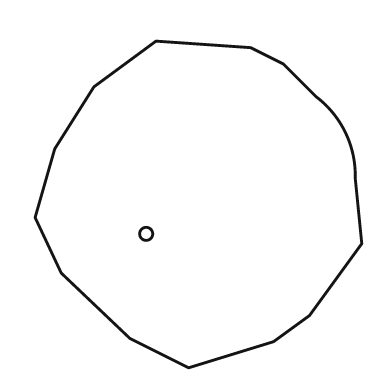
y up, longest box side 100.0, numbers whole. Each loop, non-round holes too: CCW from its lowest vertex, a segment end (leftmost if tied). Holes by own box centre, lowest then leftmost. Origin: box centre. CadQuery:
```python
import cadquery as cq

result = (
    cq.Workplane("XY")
    .moveTo(-3.0, -50.0)
    .lineTo(23.0, -42.0)
    .lineTo(34.0, -34.0)
    .lineTo(50.0, -12.0)
    .lineTo(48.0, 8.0)
    .threePointArc((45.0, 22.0), (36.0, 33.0))
    .lineTo(26.0, 43.0)
    .lineTo(16.0, 48.0)
    .lineTo(-13.0, 50.0)
    .lineTo(-32.0, 36.0)
    .lineTo(-44.0, 17.0)
    .lineTo(-50.0, -4.0)
    .lineTo(-42.0, -21.0)
    .lineTo(-21.0, -41.0)
    .close()
    .moveTo(-16.0, -9.0)
    .circle(2.0)
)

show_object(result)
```